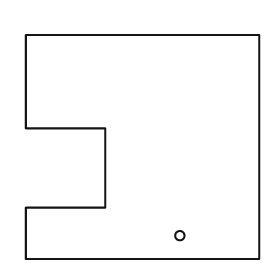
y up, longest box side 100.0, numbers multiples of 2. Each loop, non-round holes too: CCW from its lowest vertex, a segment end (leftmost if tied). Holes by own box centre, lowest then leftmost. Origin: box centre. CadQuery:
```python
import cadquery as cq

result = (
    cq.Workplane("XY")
    .moveTo(-50.0, -48.0)
    .lineTo(50.0, -48.0)
    .lineTo(50.0, 48.0)
    .lineTo(-50.0, 48.0)
    .lineTo(-50.0, 8.0)
    .lineTo(-16.0, 8.0)
    .lineTo(-16.0, -26.0)
    .lineTo(-50.0, -26.0)
    .close()
    .moveTo(16.0, -38.0)
    .circle(2.0)
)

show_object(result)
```